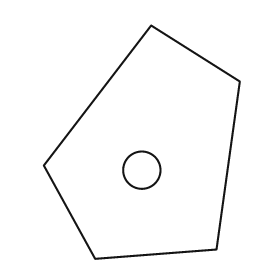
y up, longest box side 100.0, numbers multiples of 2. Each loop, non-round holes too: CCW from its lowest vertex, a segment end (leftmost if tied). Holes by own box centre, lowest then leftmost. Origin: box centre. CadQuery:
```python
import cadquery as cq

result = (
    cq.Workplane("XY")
    .moveTo(-20.0, -50.0)
    .lineTo(32.0, -46.0)
    .lineTo(42.0, 26.0)
    .lineTo(4.0, 50.0)
    .lineTo(-42.0, -10.0)
    .close()
    .moveTo(0.0, -12.0)
    .circle(8.0)
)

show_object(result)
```